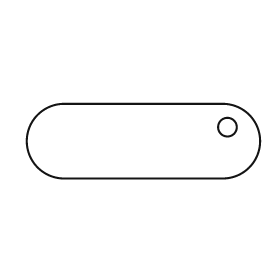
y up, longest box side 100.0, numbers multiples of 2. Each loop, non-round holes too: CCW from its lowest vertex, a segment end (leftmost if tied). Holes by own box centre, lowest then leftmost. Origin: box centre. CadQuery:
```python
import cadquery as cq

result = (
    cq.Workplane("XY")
    .moveTo(-34.0, -16.0)
    .lineTo(34.0, -16.0)
    .threePointArc((50.0, 0.0), (34.0, 16.0))
    .lineTo(-34.0, 16.0)
    .threePointArc((-50.0, 0.0), (-34.0, -16.0))
    .close()
    .moveTo(36.0, 6.0)
    .circle(4.0)
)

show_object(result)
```